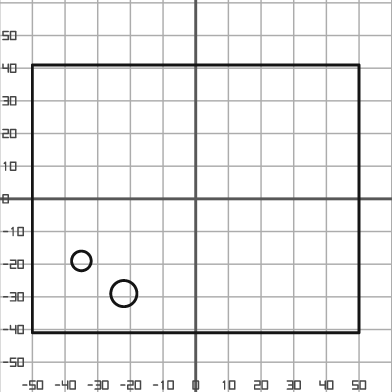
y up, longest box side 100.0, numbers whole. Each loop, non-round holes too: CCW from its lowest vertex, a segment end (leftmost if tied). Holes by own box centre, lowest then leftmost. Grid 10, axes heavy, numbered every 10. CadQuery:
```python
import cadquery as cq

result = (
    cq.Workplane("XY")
    .moveTo(-50.0, -41.0)
    .lineTo(50.0, -41.0)
    .lineTo(50.0, 41.0)
    .lineTo(-50.0, 41.0)
    .close()
    .moveTo(-22.0, -29.0)
    .circle(4.0)
    .moveTo(-35.0, -19.0)
    .circle(3.0)
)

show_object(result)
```